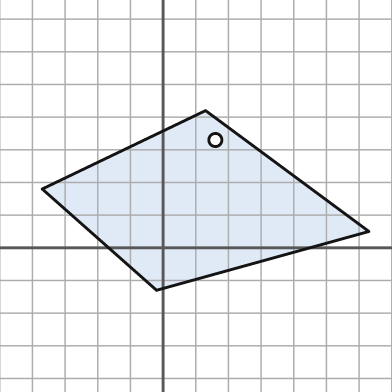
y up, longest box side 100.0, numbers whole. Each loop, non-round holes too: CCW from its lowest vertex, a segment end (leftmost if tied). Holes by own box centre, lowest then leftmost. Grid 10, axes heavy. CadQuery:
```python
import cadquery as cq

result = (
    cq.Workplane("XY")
    .moveTo(-2.0, -13.0)
    .lineTo(63.0, 5.0)
    .lineTo(13.0, 42.0)
    .lineTo(-37.0, 18.0)
    .close()
    .moveTo(16.0, 33.0)
    .circle(2.0)
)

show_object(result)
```